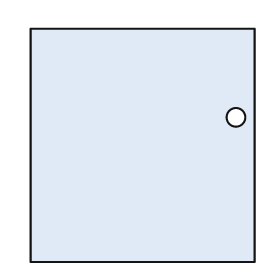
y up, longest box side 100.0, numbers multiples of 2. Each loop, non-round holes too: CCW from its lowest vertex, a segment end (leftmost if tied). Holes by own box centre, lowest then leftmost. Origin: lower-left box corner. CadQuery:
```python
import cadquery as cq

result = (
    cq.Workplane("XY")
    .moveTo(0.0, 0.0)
    .lineTo(96.0, 0.0)
    .lineTo(96.0, 100.0)
    .lineTo(0.0, 100.0)
    .close()
    .moveTo(88.0, 62.0)
    .circle(4.0)
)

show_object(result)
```